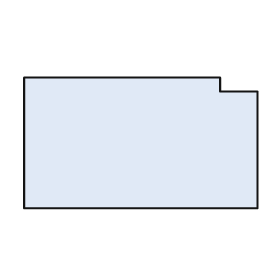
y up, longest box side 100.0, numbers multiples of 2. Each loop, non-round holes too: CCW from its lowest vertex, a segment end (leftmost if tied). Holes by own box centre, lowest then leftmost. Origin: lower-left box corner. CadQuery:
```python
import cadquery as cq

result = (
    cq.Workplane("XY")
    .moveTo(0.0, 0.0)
    .lineTo(100.0, 0.0)
    .lineTo(100.0, 50.0)
    .lineTo(84.0, 50.0)
    .lineTo(84.0, 56.0)
    .lineTo(0.0, 56.0)
    .close()
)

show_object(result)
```